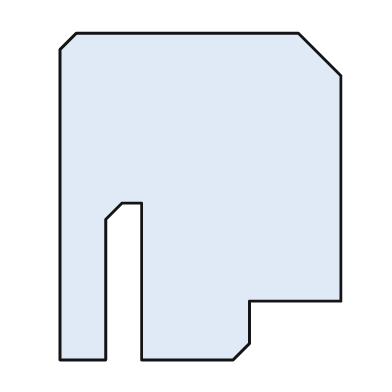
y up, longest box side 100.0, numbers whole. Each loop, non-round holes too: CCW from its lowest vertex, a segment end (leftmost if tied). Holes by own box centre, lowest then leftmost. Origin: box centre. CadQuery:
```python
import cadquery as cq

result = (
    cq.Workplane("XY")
    .moveTo(-43.0, -50.0)
    .lineTo(-29.0, -50.0)
    .lineTo(-29.0, -7.0)
    .lineTo(-24.0, -2.0)
    .lineTo(-18.0, -2.0)
    .lineTo(-18.0, -50.0)
    .lineTo(10.0, -50.0)
    .lineTo(15.0, -45.0)
    .lineTo(15.0, -32.0)
    .lineTo(43.0, -32.0)
    .lineTo(43.0, 37.0)
    .lineTo(30.0, 50.0)
    .lineTo(-38.0, 50.0)
    .lineTo(-43.0, 45.0)
    .close()
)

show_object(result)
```